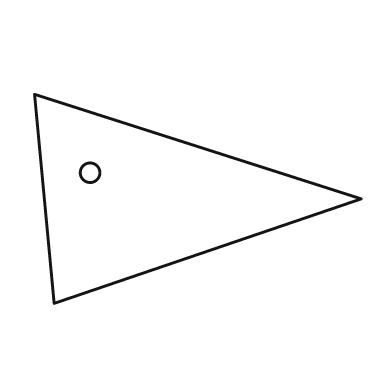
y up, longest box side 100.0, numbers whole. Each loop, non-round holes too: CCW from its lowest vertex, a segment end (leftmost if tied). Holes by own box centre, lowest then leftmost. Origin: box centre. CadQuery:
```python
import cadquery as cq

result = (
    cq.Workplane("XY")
    .moveTo(-44.0, -32.0)
    .lineTo(50.0, 0.0)
    .lineTo(-50.0, 32.0)
    .close()
    .moveTo(-33.0, 8.0)
    .circle(3.0)
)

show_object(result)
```